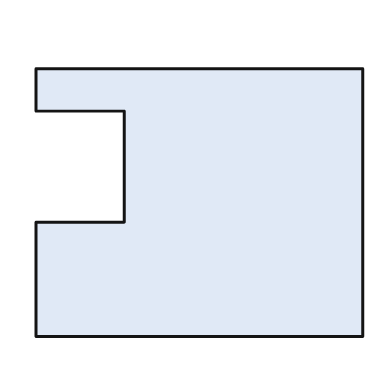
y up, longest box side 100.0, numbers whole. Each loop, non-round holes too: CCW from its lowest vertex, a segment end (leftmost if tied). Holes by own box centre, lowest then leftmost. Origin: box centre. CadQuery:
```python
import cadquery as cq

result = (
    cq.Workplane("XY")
    .moveTo(-50.0, -41.0)
    .lineTo(50.0, -41.0)
    .lineTo(50.0, 41.0)
    .lineTo(-50.0, 41.0)
    .lineTo(-50.0, 28.0)
    .lineTo(-23.0, 28.0)
    .lineTo(-23.0, -6.0)
    .lineTo(-50.0, -6.0)
    .close()
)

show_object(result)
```